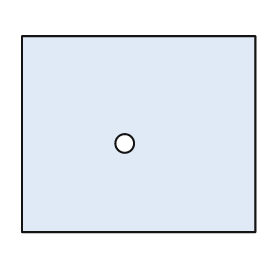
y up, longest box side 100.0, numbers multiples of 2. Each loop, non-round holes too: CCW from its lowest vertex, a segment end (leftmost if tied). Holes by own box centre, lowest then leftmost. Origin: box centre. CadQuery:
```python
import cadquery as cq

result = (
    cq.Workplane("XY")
    .moveTo(-50.0, -42.0)
    .lineTo(50.0, -42.0)
    .lineTo(50.0, 42.0)
    .lineTo(-50.0, 42.0)
    .close()
    .moveTo(-6.0, -4.0)
    .circle(4.0)
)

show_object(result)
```